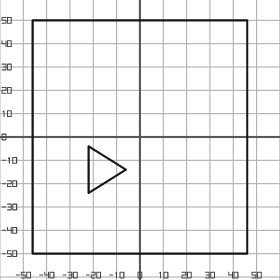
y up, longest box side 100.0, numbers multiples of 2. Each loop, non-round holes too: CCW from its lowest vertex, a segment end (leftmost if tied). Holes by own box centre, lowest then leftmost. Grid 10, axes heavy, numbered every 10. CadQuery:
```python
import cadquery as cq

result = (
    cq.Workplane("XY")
    .moveTo(-46.0, -50.0)
    .lineTo(46.0, -50.0)
    .lineTo(46.0, 50.0)
    .lineTo(-46.0, 50.0)
    .close()
    .moveTo(-22.0, -24.0)
    .lineTo(-6.0, -14.0)
    .lineTo(-22.0, -4.0)
    .close()
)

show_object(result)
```